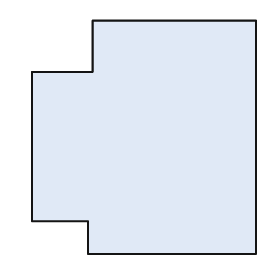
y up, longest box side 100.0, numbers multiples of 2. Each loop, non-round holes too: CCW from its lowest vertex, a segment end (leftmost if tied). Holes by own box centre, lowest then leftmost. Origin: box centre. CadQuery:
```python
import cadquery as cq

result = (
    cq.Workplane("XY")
    .moveTo(-24.0, -50.0)
    .lineTo(48.0, -50.0)
    .lineTo(48.0, 50.0)
    .lineTo(-22.0, 50.0)
    .lineTo(-22.0, 28.0)
    .lineTo(-48.0, 28.0)
    .lineTo(-48.0, -36.0)
    .lineTo(-24.0, -36.0)
    .close()
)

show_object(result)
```